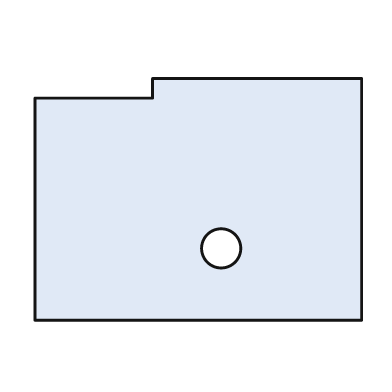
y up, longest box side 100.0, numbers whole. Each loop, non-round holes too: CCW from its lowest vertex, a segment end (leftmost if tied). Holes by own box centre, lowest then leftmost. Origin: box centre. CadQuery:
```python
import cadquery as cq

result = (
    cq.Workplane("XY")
    .moveTo(-50.0, -37.0)
    .lineTo(50.0, -37.0)
    .lineTo(50.0, 37.0)
    .lineTo(-14.0, 37.0)
    .lineTo(-14.0, 31.0)
    .lineTo(-50.0, 31.0)
    .close()
    .moveTo(7.0, -15.0)
    .circle(6.0)
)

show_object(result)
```